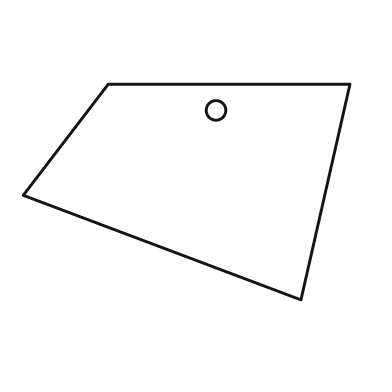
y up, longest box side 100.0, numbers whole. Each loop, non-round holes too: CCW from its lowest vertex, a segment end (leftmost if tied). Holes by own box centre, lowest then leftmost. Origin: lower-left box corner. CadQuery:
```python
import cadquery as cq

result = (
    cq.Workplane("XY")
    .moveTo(85.0, 0.0)
    .lineTo(100.0, 66.0)
    .lineTo(26.0, 66.0)
    .lineTo(0.0, 32.0)
    .close()
    .moveTo(59.0, 58.0)
    .circle(3.0)
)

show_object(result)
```